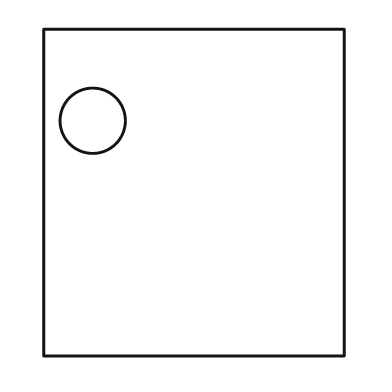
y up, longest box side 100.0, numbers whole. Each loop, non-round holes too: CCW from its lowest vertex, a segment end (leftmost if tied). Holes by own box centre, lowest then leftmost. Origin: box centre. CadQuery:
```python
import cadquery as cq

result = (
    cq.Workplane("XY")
    .moveTo(-46.0, -50.0)
    .lineTo(46.0, -50.0)
    .lineTo(46.0, 50.0)
    .lineTo(-46.0, 50.0)
    .close()
    .moveTo(-31.0, 22.0)
    .circle(10.0)
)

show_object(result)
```